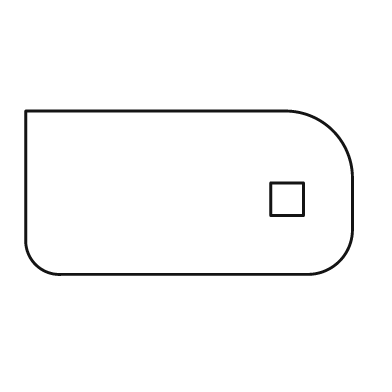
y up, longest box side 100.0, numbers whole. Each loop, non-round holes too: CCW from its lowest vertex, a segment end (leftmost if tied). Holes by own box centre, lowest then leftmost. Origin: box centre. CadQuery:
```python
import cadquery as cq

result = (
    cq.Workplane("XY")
    .moveTo(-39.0, -25.0)
    .lineTo(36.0, -25.0)
    .threePointArc((46.0, -21.0), (50.0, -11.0))
    .lineTo(50.0, 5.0)
    .threePointArc((44.0, 19.0), (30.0, 25.0))
    .lineTo(-50.0, 25.0)
    .lineTo(-50.0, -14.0)
    .threePointArc((-47.0, -22.0), (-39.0, -25.0))
    .close()
    .moveTo(25.0, -7.0)
    .lineTo(35.0, -7.0)
    .lineTo(35.0, 3.0)
    .lineTo(25.0, 3.0)
    .close()
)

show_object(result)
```